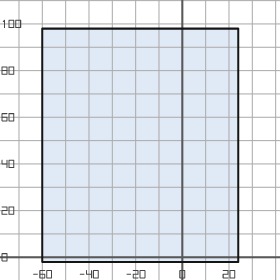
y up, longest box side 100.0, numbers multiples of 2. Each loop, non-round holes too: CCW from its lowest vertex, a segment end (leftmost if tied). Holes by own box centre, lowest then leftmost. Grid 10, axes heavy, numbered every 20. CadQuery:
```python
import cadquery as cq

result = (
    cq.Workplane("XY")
    .moveTo(-60.0, -2.0)
    .lineTo(24.0, -2.0)
    .lineTo(24.0, 98.0)
    .lineTo(-60.0, 98.0)
    .close()
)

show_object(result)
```